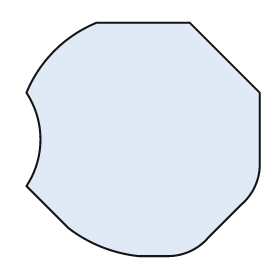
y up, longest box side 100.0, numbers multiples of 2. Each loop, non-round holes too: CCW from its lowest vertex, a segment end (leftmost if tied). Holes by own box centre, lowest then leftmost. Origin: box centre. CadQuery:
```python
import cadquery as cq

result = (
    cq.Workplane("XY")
    .moveTo(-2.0, -50.0)
    .lineTo(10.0, -50.0)
    .threePointArc((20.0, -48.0), (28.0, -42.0))
    .lineTo(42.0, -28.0)
    .threePointArc((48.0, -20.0), (50.0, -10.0))
    .lineTo(50.0, 20.0)
    .lineTo(20.0, 50.0)
    .lineTo(-20.0, 50.0)
    .threePointArc((-38.0, 38.0), (-50.0, 20.0))
    .threePointArc((-44.0, 0.0), (-50.0, -20.0))
    .lineTo(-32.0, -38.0)
    .threePointArc((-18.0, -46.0), (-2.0, -50.0))
    .close()
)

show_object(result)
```